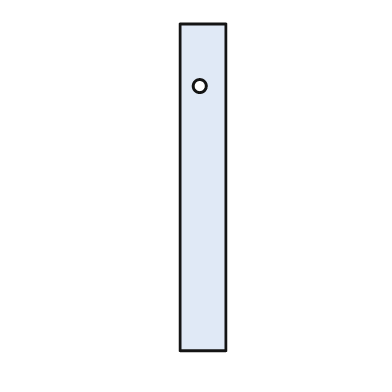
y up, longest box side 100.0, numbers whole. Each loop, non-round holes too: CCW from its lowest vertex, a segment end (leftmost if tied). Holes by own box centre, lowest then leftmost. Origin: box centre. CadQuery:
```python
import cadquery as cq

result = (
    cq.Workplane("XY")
    .moveTo(-7.0, -50.0)
    .lineTo(7.0, -50.0)
    .lineTo(7.0, 50.0)
    .lineTo(-7.0, 50.0)
    .close()
    .moveTo(-1.0, 31.0)
    .circle(2.0)
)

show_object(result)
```